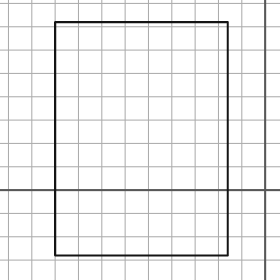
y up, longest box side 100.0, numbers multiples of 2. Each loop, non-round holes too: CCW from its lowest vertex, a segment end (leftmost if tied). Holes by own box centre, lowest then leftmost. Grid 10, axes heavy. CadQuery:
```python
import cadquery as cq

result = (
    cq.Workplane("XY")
    .moveTo(-90.0, -28.0)
    .lineTo(-16.0, -28.0)
    .lineTo(-16.0, 72.0)
    .lineTo(-90.0, 72.0)
    .close()
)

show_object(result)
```